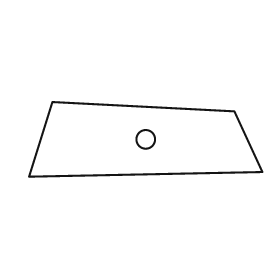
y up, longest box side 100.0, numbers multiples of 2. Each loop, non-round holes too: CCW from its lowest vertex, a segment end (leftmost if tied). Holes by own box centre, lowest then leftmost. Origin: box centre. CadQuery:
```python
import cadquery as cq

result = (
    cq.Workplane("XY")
    .moveTo(-50.0, -16.0)
    .lineTo(50.0, -14.0)
    .lineTo(38.0, 12.0)
    .lineTo(-40.0, 16.0)
    .close()
    .moveTo(0.0, 0.0)
    .circle(4.0)
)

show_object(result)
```